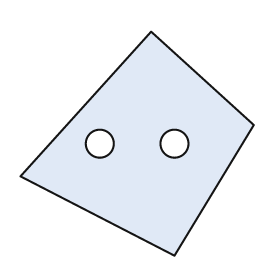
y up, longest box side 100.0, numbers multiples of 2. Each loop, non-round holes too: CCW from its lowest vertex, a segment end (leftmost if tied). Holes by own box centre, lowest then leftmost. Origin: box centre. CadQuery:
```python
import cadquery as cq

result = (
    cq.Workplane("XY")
    .moveTo(16.0, -48.0)
    .lineTo(50.0, 8.0)
    .lineTo(6.0, 48.0)
    .lineTo(-50.0, -14.0)
    .close()
    .moveTo(-16.0, 0.0)
    .circle(6.0)
    .moveTo(16.0, 0.0)
    .circle(6.0)
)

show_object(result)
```